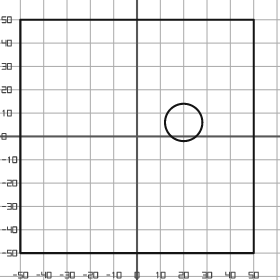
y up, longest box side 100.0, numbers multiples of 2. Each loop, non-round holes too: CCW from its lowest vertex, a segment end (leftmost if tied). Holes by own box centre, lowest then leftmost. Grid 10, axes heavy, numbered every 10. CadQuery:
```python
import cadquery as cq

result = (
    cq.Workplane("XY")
    .moveTo(-50.0, -50.0)
    .lineTo(50.0, -50.0)
    .lineTo(50.0, 50.0)
    .lineTo(-50.0, 50.0)
    .close()
    .moveTo(20.0, 6.0)
    .circle(8.0)
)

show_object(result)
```